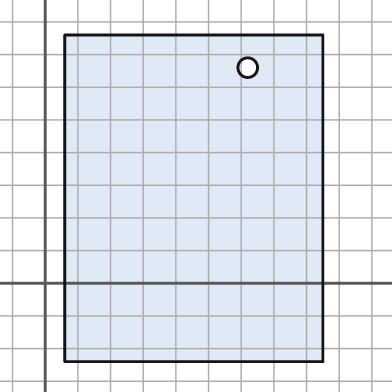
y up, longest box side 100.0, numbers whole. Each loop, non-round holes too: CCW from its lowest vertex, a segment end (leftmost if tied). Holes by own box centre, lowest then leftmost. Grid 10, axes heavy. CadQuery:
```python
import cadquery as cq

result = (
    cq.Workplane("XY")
    .moveTo(6.0, -24.0)
    .lineTo(85.0, -24.0)
    .lineTo(85.0, 76.0)
    .lineTo(6.0, 76.0)
    .close()
    .moveTo(62.0, 66.0)
    .circle(3.0)
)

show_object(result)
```